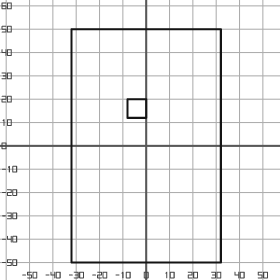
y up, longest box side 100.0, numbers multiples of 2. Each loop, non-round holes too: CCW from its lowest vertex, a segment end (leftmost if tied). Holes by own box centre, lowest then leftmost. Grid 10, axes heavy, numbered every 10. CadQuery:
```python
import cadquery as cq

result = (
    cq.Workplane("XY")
    .moveTo(-32.0, -50.0)
    .lineTo(32.0, -50.0)
    .lineTo(32.0, 50.0)
    .lineTo(-32.0, 50.0)
    .close()
    .moveTo(-8.0, 12.0)
    .lineTo(0.0, 12.0)
    .lineTo(0.0, 20.0)
    .lineTo(-8.0, 20.0)
    .close()
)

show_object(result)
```